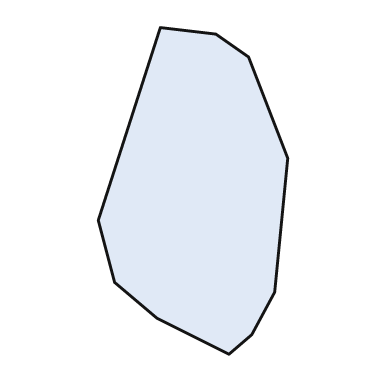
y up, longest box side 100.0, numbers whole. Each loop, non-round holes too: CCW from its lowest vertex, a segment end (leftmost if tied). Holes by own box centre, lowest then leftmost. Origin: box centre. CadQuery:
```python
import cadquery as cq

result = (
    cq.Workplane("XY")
    .moveTo(11.0, -50.0)
    .lineTo(18.0, -44.0)
    .lineTo(25.0, -31.0)
    .lineTo(29.0, 10.0)
    .lineTo(17.0, 41.0)
    .lineTo(7.0, 48.0)
    .lineTo(-10.0, 50.0)
    .lineTo(-29.0, -9.0)
    .lineTo(-24.0, -28.0)
    .lineTo(-11.0, -39.0)
    .close()
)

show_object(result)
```